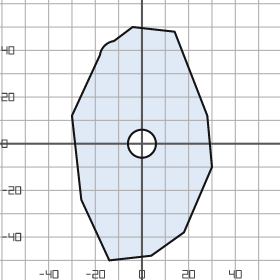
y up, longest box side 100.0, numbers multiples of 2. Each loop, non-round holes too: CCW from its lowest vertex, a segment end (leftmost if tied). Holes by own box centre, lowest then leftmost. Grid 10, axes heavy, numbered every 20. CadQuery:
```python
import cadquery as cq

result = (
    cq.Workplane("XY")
    .moveTo(-14.0, -50.0)
    .lineTo(4.0, -48.0)
    .lineTo(18.0, -38.0)
    .lineTo(30.0, -10.0)
    .lineTo(28.0, 12.0)
    .lineTo(14.0, 48.0)
    .lineTo(-4.0, 50.0)
    .lineTo(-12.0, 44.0)
    .threePointArc((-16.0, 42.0), (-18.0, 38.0))
    .lineTo(-30.0, 12.0)
    .lineTo(-26.0, -24.0)
    .close()
    .moveTo(0.0, 0.0)
    .circle(6.0)
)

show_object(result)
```